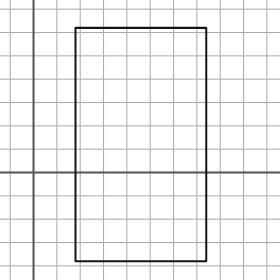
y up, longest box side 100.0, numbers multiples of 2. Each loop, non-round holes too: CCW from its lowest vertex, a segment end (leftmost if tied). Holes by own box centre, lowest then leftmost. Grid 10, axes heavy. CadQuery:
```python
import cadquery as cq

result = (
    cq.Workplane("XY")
    .moveTo(18.0, -38.0)
    .lineTo(74.0, -38.0)
    .lineTo(74.0, 62.0)
    .lineTo(18.0, 62.0)
    .close()
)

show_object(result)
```